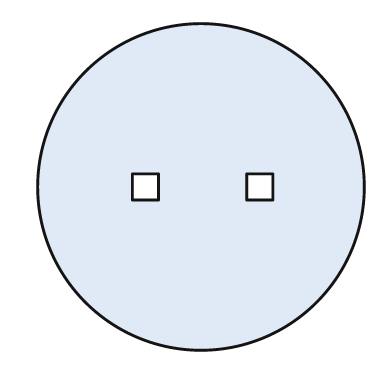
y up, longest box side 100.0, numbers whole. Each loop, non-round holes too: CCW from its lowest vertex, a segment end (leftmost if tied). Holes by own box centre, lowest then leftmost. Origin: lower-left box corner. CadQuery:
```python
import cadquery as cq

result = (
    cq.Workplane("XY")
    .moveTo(50.0, 50.0)
    .circle(50.0)
    .moveTo(29.0, 46.0)
    .lineTo(37.0, 46.0)
    .lineTo(37.0, 54.0)
    .lineTo(29.0, 54.0)
    .close()
    .moveTo(64.0, 46.0)
    .lineTo(72.0, 46.0)
    .lineTo(72.0, 54.0)
    .lineTo(64.0, 54.0)
    .close()
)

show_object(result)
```